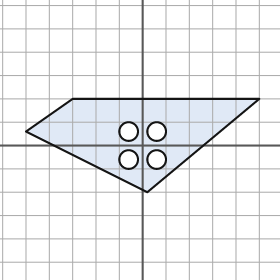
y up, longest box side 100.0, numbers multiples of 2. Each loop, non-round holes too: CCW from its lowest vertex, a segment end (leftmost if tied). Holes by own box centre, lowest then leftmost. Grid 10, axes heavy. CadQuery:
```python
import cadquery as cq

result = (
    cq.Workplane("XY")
    .moveTo(2.0, -20.0)
    .lineTo(50.0, 20.0)
    .lineTo(-30.0, 20.0)
    .lineTo(-50.0, 6.0)
    .close()
    .moveTo(-6.0, -6.0)
    .circle(4.0)
    .moveTo(6.0, -6.0)
    .circle(4.0)
    .moveTo(-6.0, 6.0)
    .circle(4.0)
    .moveTo(6.0, 6.0)
    .circle(4.0)
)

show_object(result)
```